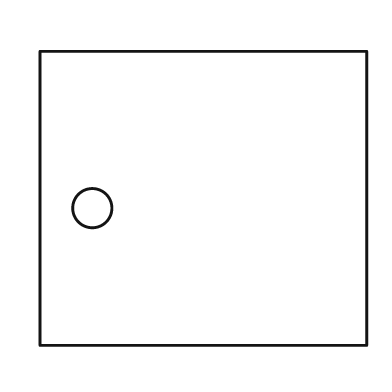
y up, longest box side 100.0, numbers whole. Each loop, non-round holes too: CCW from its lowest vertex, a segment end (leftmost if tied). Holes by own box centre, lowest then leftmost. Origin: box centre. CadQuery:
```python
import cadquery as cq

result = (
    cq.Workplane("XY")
    .moveTo(-50.0, -45.0)
    .lineTo(50.0, -45.0)
    .lineTo(50.0, 45.0)
    .lineTo(-50.0, 45.0)
    .close()
    .moveTo(-34.0, -3.0)
    .circle(6.0)
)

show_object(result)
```